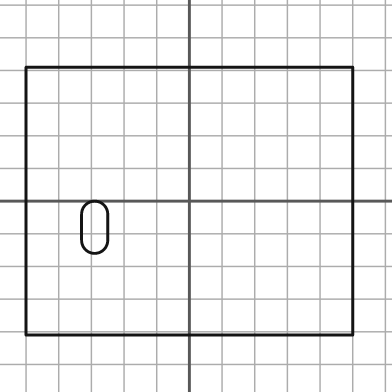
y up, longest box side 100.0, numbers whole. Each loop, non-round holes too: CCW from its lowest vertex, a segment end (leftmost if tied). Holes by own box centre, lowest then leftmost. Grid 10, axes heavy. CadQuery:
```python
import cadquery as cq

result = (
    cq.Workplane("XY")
    .moveTo(-50.0, -41.0)
    .lineTo(50.0, -41.0)
    .lineTo(50.0, 41.0)
    .lineTo(-50.0, 41.0)
    .close()
    .moveTo(-33.0, -12.0)
    .threePointArc((-29.0, -16.0), (-25.0, -12.0))
    .lineTo(-25.0, -4.0)
    .threePointArc((-29.0, 0.0), (-33.0, -4.0))
    .close()
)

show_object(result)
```